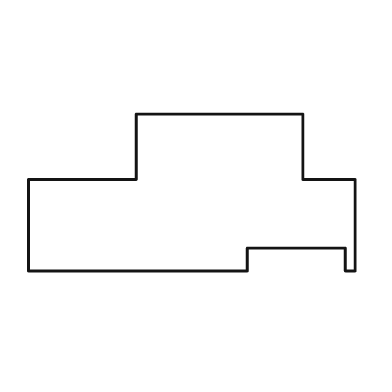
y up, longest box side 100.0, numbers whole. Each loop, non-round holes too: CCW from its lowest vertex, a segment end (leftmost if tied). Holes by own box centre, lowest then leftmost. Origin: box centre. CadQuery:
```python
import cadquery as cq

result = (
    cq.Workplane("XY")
    .moveTo(-50.0, -24.0)
    .lineTo(17.0, -24.0)
    .lineTo(17.0, -17.0)
    .lineTo(47.0, -17.0)
    .lineTo(47.0, -24.0)
    .lineTo(50.0, -24.0)
    .lineTo(50.0, 4.0)
    .lineTo(34.0, 4.0)
    .lineTo(34.0, 24.0)
    .lineTo(-17.0, 24.0)
    .lineTo(-17.0, 4.0)
    .lineTo(-50.0, 4.0)
    .close()
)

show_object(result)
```